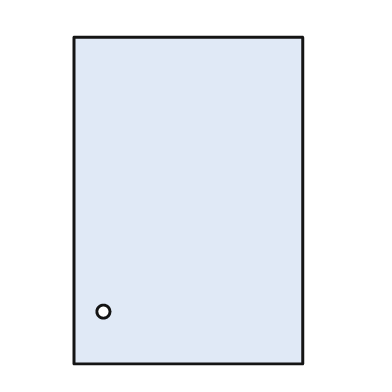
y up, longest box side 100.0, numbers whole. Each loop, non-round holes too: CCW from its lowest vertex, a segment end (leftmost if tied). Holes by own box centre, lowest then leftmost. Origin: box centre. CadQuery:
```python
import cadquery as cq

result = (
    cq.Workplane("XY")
    .moveTo(-35.0, -50.0)
    .lineTo(35.0, -50.0)
    .lineTo(35.0, 50.0)
    .lineTo(-35.0, 50.0)
    .close()
    .moveTo(-26.0, -34.0)
    .circle(2.0)
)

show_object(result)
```